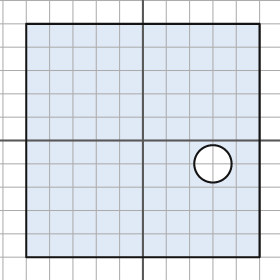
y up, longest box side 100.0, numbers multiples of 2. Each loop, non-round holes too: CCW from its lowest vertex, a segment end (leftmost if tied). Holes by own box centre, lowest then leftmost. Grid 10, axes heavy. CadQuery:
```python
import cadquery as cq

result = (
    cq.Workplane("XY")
    .moveTo(-50.0, -50.0)
    .lineTo(50.0, -50.0)
    .lineTo(50.0, 50.0)
    .lineTo(-50.0, 50.0)
    .close()
    .moveTo(30.0, -10.0)
    .circle(8.0)
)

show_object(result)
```